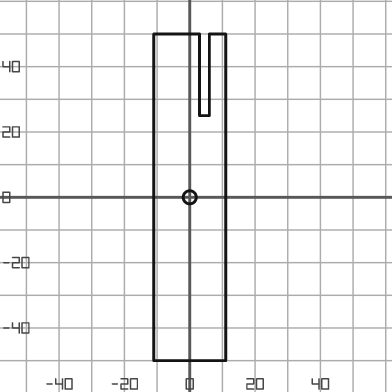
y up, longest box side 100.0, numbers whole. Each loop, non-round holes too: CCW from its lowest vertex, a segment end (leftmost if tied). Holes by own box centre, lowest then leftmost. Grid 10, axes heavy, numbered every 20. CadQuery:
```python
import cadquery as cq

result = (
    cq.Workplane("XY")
    .moveTo(-11.0, -50.0)
    .lineTo(11.0, -50.0)
    .lineTo(11.0, 50.0)
    .lineTo(6.0, 50.0)
    .lineTo(6.0, 25.0)
    .lineTo(3.0, 25.0)
    .lineTo(3.0, 50.0)
    .lineTo(-11.0, 50.0)
    .close()
    .moveTo(0.0, 0.0)
    .circle(2.0)
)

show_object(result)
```